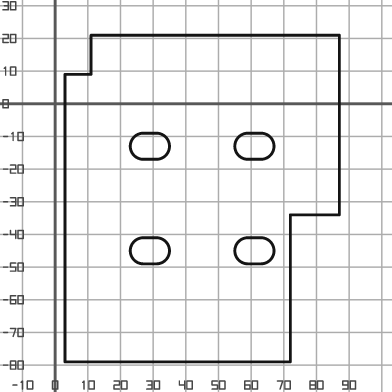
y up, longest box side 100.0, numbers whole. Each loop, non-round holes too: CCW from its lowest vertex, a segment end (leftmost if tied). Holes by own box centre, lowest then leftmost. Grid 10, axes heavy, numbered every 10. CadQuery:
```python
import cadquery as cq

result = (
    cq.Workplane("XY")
    .moveTo(3.0, -79.0)
    .lineTo(72.0, -79.0)
    .lineTo(72.0, -34.0)
    .lineTo(87.0, -34.0)
    .lineTo(87.0, 21.0)
    .lineTo(11.0, 21.0)
    .lineTo(11.0, 9.0)
    .lineTo(3.0, 9.0)
    .close()
    .moveTo(27.0, -49.0)
    .lineTo(31.0, -49.0)
    .threePointArc((35.0, -45.0), (31.0, -41.0))
    .lineTo(27.0, -41.0)
    .threePointArc((23.0, -45.0), (27.0, -49.0))
    .close()
    .moveTo(59.0, -49.0)
    .lineTo(63.0, -49.0)
    .threePointArc((67.0, -45.0), (63.0, -41.0))
    .lineTo(59.0, -41.0)
    .threePointArc((55.0, -45.0), (59.0, -49.0))
    .close()
    .moveTo(27.0, -17.0)
    .lineTo(31.0, -17.0)
    .threePointArc((35.0, -13.0), (31.0, -9.0))
    .lineTo(27.0, -9.0)
    .threePointArc((23.0, -13.0), (27.0, -17.0))
    .close()
    .moveTo(59.0, -17.0)
    .lineTo(63.0, -17.0)
    .threePointArc((67.0, -13.0), (63.0, -9.0))
    .lineTo(59.0, -9.0)
    .threePointArc((55.0, -13.0), (59.0, -17.0))
    .close()
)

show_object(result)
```